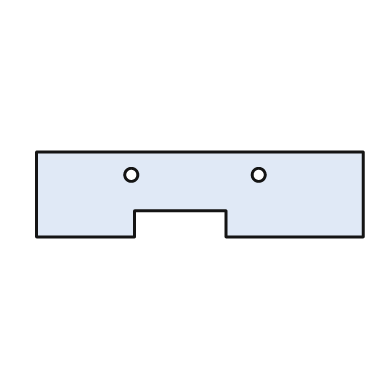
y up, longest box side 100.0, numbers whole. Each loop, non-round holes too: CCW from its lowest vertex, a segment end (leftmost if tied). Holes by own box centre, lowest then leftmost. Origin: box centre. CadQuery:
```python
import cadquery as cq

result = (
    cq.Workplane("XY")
    .moveTo(-50.0, -13.0)
    .lineTo(-20.0, -13.0)
    .lineTo(-20.0, -5.0)
    .lineTo(8.0, -5.0)
    .lineTo(8.0, -13.0)
    .lineTo(50.0, -13.0)
    .lineTo(50.0, 13.0)
    .lineTo(-50.0, 13.0)
    .close()
    .moveTo(-21.0, 6.0)
    .circle(2.0)
    .moveTo(18.0, 6.0)
    .circle(2.0)
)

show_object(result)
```